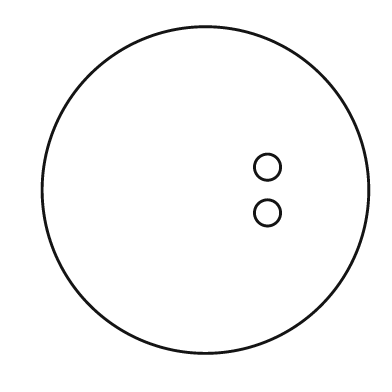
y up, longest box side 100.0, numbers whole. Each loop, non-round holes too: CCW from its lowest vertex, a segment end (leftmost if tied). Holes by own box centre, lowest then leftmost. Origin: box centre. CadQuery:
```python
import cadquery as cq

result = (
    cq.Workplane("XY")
    .moveTo(0.0, 0.0)
    .circle(50.0)
    .moveTo(19.0, -7.0)
    .circle(4.0)
    .moveTo(19.0, 7.0)
    .circle(4.0)
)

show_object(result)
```